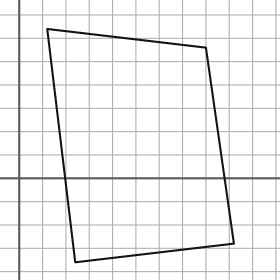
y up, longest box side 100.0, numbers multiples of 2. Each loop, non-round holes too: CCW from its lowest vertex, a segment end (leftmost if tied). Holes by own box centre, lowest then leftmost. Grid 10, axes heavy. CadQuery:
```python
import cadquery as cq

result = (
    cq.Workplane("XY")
    .moveTo(24.0, -36.0)
    .lineTo(92.0, -28.0)
    .lineTo(80.0, 56.0)
    .lineTo(12.0, 64.0)
    .close()
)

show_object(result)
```